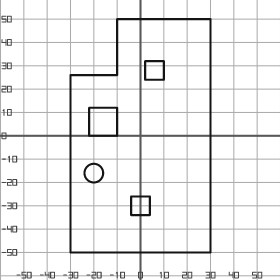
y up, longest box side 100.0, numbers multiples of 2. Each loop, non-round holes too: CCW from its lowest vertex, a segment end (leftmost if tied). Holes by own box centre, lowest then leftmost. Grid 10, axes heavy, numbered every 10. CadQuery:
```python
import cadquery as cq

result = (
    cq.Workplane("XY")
    .moveTo(-30.0, -50.0)
    .lineTo(30.0, -50.0)
    .lineTo(30.0, 50.0)
    .lineTo(-10.0, 50.0)
    .lineTo(-10.0, 26.0)
    .lineTo(-30.0, 26.0)
    .close()
    .moveTo(-4.0, -34.0)
    .lineTo(4.0, -34.0)
    .lineTo(4.0, -26.0)
    .lineTo(-4.0, -26.0)
    .close()
    .moveTo(-20.0, -16.0)
    .circle(4.0)
    .moveTo(-22.0, 0.0)
    .lineTo(-10.0, 0.0)
    .lineTo(-10.0, 12.0)
    .lineTo(-22.0, 12.0)
    .close()
    .moveTo(2.0, 24.0)
    .lineTo(10.0, 24.0)
    .lineTo(10.0, 32.0)
    .lineTo(2.0, 32.0)
    .close()
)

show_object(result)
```